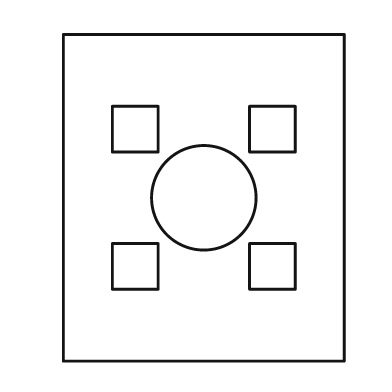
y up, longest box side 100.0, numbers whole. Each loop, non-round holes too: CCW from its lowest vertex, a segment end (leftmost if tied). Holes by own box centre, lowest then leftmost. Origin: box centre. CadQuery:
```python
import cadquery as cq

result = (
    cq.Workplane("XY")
    .moveTo(-43.0, -50.0)
    .lineTo(43.0, -50.0)
    .lineTo(43.0, 50.0)
    .lineTo(-43.0, 50.0)
    .close()
    .moveTo(-28.0, -28.0)
    .lineTo(-14.0, -28.0)
    .lineTo(-14.0, -14.0)
    .lineTo(-28.0, -14.0)
    .close()
    .moveTo(14.0, -28.0)
    .lineTo(28.0, -28.0)
    .lineTo(28.0, -14.0)
    .lineTo(14.0, -14.0)
    .close()
    .moveTo(0.0, 0.0)
    .circle(16.0)
    .moveTo(-28.0, 14.0)
    .lineTo(-14.0, 14.0)
    .lineTo(-14.0, 28.0)
    .lineTo(-28.0, 28.0)
    .close()
    .moveTo(14.0, 14.0)
    .lineTo(28.0, 14.0)
    .lineTo(28.0, 28.0)
    .lineTo(14.0, 28.0)
    .close()
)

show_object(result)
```